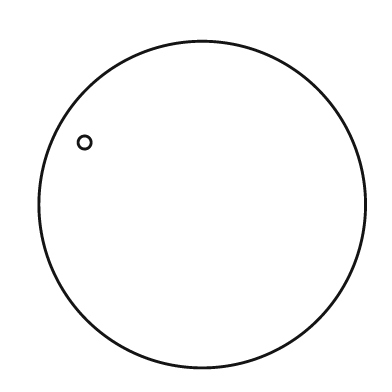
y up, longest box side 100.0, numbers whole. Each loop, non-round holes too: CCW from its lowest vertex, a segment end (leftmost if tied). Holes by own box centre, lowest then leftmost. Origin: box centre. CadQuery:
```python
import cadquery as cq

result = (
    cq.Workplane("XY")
    .moveTo(0.0, 0.0)
    .circle(50.0)
    .moveTo(-36.0, 19.0)
    .circle(2.0)
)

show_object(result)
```